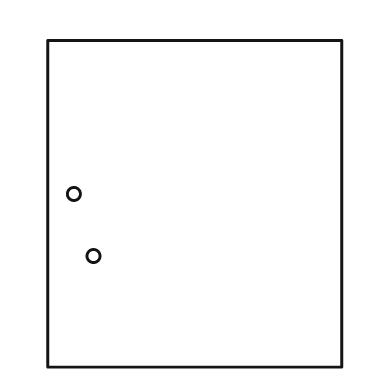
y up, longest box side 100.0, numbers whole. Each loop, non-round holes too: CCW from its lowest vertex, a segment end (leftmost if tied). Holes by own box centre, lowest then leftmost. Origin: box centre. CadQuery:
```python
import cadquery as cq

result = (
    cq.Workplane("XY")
    .moveTo(-45.0, -50.0)
    .lineTo(45.0, -50.0)
    .lineTo(45.0, 50.0)
    .lineTo(-45.0, 50.0)
    .close()
    .moveTo(-31.0, -16.0)
    .circle(2.0)
    .moveTo(-37.0, 3.0)
    .circle(2.0)
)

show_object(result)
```